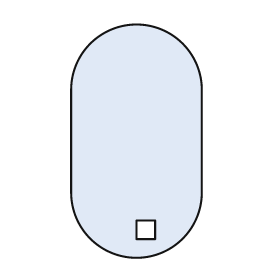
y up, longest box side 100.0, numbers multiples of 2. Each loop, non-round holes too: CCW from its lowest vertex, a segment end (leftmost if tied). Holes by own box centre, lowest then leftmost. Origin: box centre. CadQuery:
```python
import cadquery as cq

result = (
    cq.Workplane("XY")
    .moveTo(-28.0, -22.0)
    .threePointArc((0.0, -50.0), (28.0, -22.0))
    .lineTo(28.0, 22.0)
    .threePointArc((0.0, 50.0), (-28.0, 22.0))
    .close()
    .moveTo(0.0, -42.0)
    .lineTo(8.0, -42.0)
    .lineTo(8.0, -34.0)
    .lineTo(0.0, -34.0)
    .close()
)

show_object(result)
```